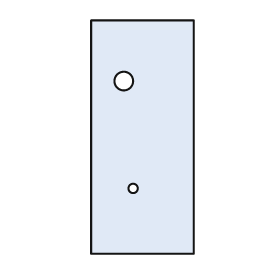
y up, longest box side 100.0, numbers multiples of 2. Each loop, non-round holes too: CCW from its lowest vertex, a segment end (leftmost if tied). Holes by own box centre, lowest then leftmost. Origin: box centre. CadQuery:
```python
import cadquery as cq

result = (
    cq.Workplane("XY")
    .moveTo(-22.0, -50.0)
    .lineTo(22.0, -50.0)
    .lineTo(22.0, 50.0)
    .lineTo(-22.0, 50.0)
    .close()
    .moveTo(-4.0, -22.0)
    .circle(2.0)
    .moveTo(-8.0, 24.0)
    .circle(4.0)
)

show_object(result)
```